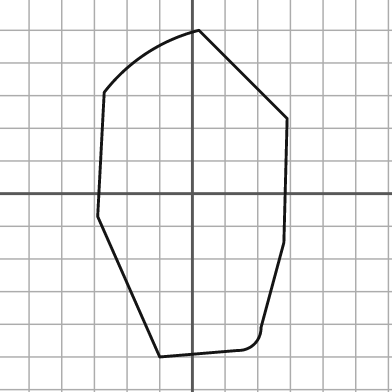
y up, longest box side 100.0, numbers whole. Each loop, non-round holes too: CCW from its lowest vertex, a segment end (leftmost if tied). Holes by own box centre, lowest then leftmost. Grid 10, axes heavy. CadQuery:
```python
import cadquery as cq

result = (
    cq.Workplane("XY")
    .moveTo(-10.0, -50.0)
    .lineTo(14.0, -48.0)
    .threePointArc((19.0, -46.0), (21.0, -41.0))
    .lineTo(28.0, -15.0)
    .lineTo(29.0, 23.0)
    .lineTo(2.0, 50.0)
    .threePointArc((-14.0, 43.0), (-27.0, 31.0))
    .lineTo(-29.0, -7.0)
    .close()
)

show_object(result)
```